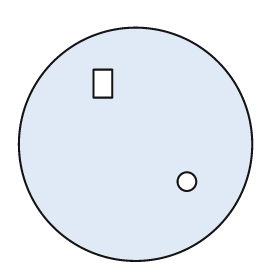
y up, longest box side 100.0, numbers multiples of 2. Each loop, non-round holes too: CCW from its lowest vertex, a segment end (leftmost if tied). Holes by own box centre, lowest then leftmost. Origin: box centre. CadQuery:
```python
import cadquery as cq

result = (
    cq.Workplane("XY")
    .moveTo(0.0, 0.0)
    .circle(50.0)
    .moveTo(22.0, -16.0)
    .circle(4.0)
    .moveTo(-18.0, 20.0)
    .lineTo(-10.0, 20.0)
    .lineTo(-10.0, 32.0)
    .lineTo(-18.0, 32.0)
    .close()
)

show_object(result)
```